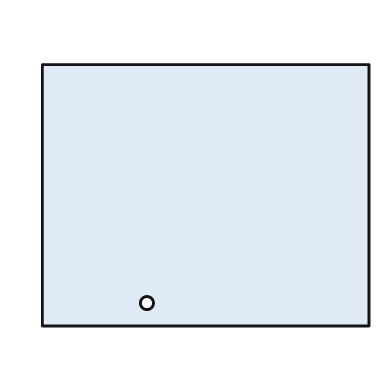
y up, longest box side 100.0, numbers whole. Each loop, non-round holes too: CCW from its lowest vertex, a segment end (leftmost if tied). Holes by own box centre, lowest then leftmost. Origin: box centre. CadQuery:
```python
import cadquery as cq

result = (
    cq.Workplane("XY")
    .moveTo(-50.0, -40.0)
    .lineTo(50.0, -40.0)
    .lineTo(50.0, 40.0)
    .lineTo(-50.0, 40.0)
    .close()
    .moveTo(-18.0, -33.0)
    .circle(2.0)
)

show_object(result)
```